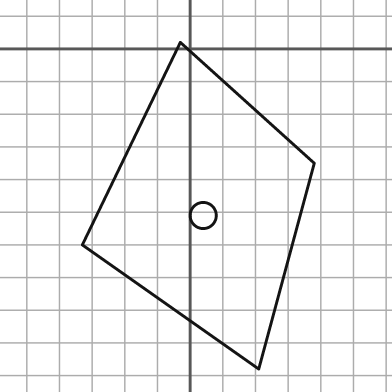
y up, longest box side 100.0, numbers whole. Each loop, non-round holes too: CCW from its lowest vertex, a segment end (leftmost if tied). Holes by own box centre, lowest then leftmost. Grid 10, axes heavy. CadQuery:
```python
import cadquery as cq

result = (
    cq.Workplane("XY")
    .moveTo(21.0, -98.0)
    .lineTo(38.0, -35.0)
    .lineTo(-3.0, 2.0)
    .lineTo(-33.0, -60.0)
    .close()
    .moveTo(4.0, -51.0)
    .circle(4.0)
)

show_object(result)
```